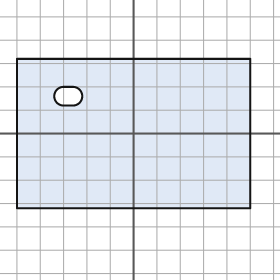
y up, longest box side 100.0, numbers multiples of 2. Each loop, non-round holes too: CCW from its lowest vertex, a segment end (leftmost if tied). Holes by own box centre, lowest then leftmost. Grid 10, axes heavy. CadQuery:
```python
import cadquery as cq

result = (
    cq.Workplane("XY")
    .moveTo(-50.0, -32.0)
    .lineTo(50.0, -32.0)
    .lineTo(50.0, 32.0)
    .lineTo(-50.0, 32.0)
    .close()
    .moveTo(-30.0, 12.0)
    .lineTo(-26.0, 12.0)
    .threePointArc((-22.0, 16.0), (-26.0, 20.0))
    .lineTo(-30.0, 20.0)
    .threePointArc((-34.0, 16.0), (-30.0, 12.0))
    .close()
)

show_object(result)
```